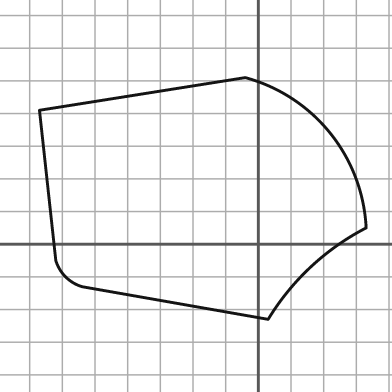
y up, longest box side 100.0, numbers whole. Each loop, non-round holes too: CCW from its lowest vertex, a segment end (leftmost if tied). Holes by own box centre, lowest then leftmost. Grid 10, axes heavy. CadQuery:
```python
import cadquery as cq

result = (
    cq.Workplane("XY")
    .moveTo(3.0, -23.0)
    .threePointArc((16.0, -7.0), (33.0, 5.0))
    .threePointArc((22.0, 34.0), (-4.0, 51.0))
    .lineTo(-67.0, 41.0)
    .lineTo(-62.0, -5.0)
    .threePointArc((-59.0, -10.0), (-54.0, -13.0))
    .close()
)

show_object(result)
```